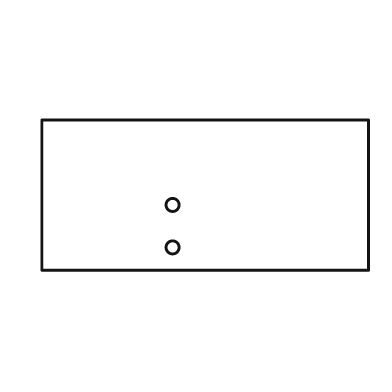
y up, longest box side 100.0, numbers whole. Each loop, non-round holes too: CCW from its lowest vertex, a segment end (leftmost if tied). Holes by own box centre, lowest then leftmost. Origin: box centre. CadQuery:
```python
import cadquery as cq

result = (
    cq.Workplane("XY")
    .moveTo(-50.0, -23.0)
    .lineTo(50.0, -23.0)
    .lineTo(50.0, 23.0)
    .lineTo(-50.0, 23.0)
    .close()
    .moveTo(-10.0, -16.0)
    .circle(2.0)
    .moveTo(-10.0, -3.0)
    .circle(2.0)
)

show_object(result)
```